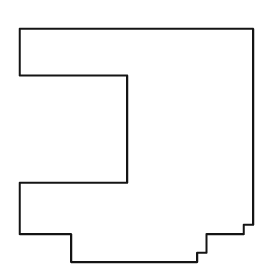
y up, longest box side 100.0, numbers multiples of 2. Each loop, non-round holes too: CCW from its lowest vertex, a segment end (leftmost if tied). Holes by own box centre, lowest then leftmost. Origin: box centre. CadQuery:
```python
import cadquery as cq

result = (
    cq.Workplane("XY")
    .moveTo(-28.0, -50.0)
    .lineTo(26.0, -50.0)
    .lineTo(26.0, -46.0)
    .lineTo(30.0, -46.0)
    .lineTo(30.0, -38.0)
    .lineTo(46.0, -38.0)
    .lineTo(46.0, -34.0)
    .lineTo(50.0, -34.0)
    .lineTo(50.0, 50.0)
    .lineTo(-50.0, 50.0)
    .lineTo(-50.0, 30.0)
    .lineTo(-4.0, 30.0)
    .lineTo(-4.0, -16.0)
    .lineTo(-50.0, -16.0)
    .lineTo(-50.0, -38.0)
    .lineTo(-28.0, -38.0)
    .close()
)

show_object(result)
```